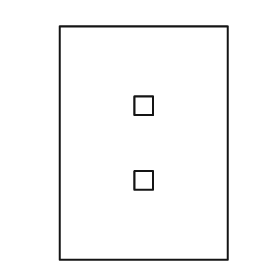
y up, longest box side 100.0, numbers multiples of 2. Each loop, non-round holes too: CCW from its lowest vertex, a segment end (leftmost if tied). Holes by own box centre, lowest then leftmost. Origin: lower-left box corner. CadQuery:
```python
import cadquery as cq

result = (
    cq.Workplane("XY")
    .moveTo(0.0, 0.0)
    .lineTo(72.0, 0.0)
    .lineTo(72.0, 100.0)
    .lineTo(0.0, 100.0)
    .close()
    .moveTo(32.0, 30.0)
    .lineTo(40.0, 30.0)
    .lineTo(40.0, 38.0)
    .lineTo(32.0, 38.0)
    .close()
    .moveTo(32.0, 62.0)
    .lineTo(40.0, 62.0)
    .lineTo(40.0, 70.0)
    .lineTo(32.0, 70.0)
    .close()
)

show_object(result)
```